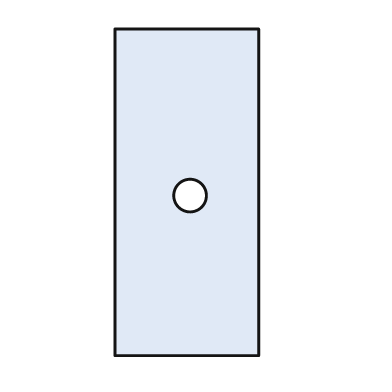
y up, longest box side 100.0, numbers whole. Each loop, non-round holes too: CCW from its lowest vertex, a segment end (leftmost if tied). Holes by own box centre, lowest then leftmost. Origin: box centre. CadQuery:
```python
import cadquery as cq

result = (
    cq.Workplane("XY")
    .moveTo(-22.0, -50.0)
    .lineTo(22.0, -50.0)
    .lineTo(22.0, 50.0)
    .lineTo(-22.0, 50.0)
    .close()
    .moveTo(1.0, -1.0)
    .circle(5.0)
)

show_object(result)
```